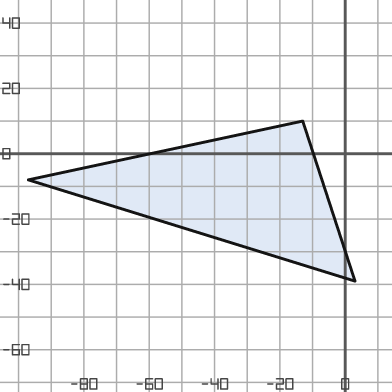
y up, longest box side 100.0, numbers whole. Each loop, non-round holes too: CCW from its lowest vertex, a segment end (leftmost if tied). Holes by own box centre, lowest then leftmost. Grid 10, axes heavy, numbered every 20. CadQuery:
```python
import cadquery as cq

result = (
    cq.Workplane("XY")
    .moveTo(3.0, -39.0)
    .lineTo(-13.0, 10.0)
    .lineTo(-97.0, -8.0)
    .close()
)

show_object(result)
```